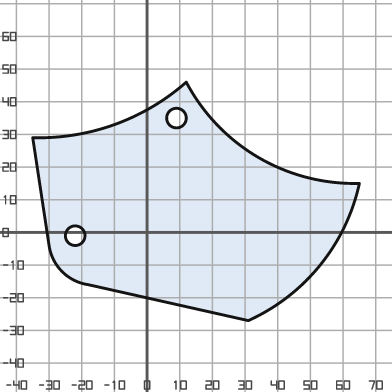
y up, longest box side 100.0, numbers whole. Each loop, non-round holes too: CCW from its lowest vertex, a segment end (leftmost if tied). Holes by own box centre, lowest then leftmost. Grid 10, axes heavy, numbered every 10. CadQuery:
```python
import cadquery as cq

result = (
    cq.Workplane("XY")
    .moveTo(31.0, -27.0)
    .threePointArc((53.0, -10.0), (65.0, 15.0))
    .threePointArc((34.0, 23.0), (12.0, 46.0))
    .threePointArc((-10.0, 33.0), (-35.0, 29.0))
    .lineTo(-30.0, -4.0)
    .threePointArc((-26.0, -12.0), (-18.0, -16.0))
    .close()
    .moveTo(-22.0, -1.0)
    .circle(3.0)
    .moveTo(9.0, 35.0)
    .circle(3.0)
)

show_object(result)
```